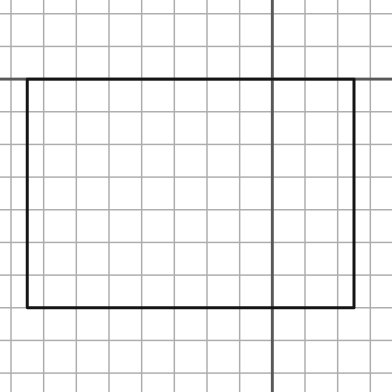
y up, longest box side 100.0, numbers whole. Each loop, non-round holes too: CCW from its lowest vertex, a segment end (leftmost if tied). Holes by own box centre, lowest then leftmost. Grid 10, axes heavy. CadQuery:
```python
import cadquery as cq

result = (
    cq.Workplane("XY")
    .moveTo(-75.0, -70.0)
    .lineTo(25.0, -70.0)
    .lineTo(25.0, 0.0)
    .lineTo(-75.0, 0.0)
    .close()
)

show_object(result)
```